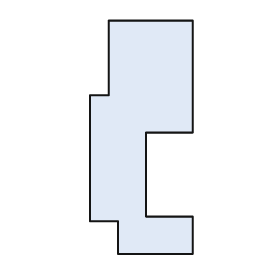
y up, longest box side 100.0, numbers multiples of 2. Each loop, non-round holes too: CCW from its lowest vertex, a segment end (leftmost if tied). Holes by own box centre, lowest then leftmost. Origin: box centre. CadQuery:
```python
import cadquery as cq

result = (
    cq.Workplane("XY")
    .moveTo(-10.0, -50.0)
    .lineTo(22.0, -50.0)
    .lineTo(22.0, -34.0)
    .lineTo(2.0, -34.0)
    .lineTo(2.0, 2.0)
    .lineTo(22.0, 2.0)
    .lineTo(22.0, 50.0)
    .lineTo(-14.0, 50.0)
    .lineTo(-14.0, 18.0)
    .lineTo(-22.0, 18.0)
    .lineTo(-22.0, -36.0)
    .lineTo(-10.0, -36.0)
    .close()
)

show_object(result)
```